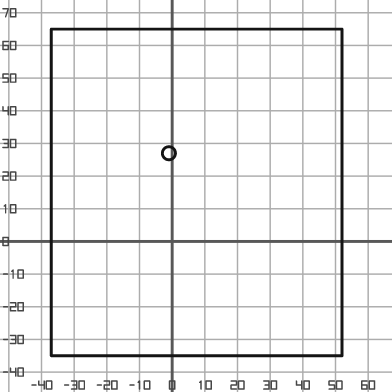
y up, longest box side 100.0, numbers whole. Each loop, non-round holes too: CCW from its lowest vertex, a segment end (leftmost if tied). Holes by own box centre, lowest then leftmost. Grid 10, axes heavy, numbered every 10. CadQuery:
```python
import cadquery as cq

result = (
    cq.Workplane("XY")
    .moveTo(-37.0, -35.0)
    .lineTo(52.0, -35.0)
    .lineTo(52.0, 65.0)
    .lineTo(-37.0, 65.0)
    .close()
    .moveTo(-1.0, 27.0)
    .circle(2.0)
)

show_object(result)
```